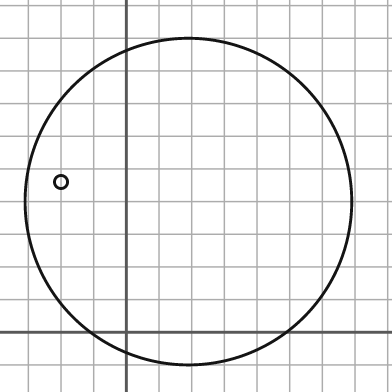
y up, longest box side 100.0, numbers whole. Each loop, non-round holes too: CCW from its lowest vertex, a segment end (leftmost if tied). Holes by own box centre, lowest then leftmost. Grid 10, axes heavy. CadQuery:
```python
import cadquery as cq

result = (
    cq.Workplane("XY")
    .moveTo(19.0, 40.0)
    .circle(50.0)
    .moveTo(-20.0, 46.0)
    .circle(2.0)
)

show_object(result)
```